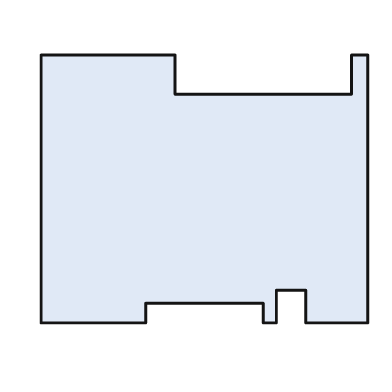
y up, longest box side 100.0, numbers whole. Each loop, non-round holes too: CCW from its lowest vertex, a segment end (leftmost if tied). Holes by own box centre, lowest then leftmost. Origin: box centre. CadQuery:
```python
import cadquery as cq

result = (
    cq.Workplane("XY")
    .moveTo(-50.0, -41.0)
    .lineTo(-18.0, -41.0)
    .lineTo(-18.0, -35.0)
    .lineTo(18.0, -35.0)
    .lineTo(18.0, -41.0)
    .lineTo(22.0, -41.0)
    .lineTo(22.0, -31.0)
    .lineTo(31.0, -31.0)
    .lineTo(31.0, -41.0)
    .lineTo(50.0, -41.0)
    .lineTo(50.0, 41.0)
    .lineTo(45.0, 41.0)
    .lineTo(45.0, 29.0)
    .lineTo(-9.0, 29.0)
    .lineTo(-9.0, 41.0)
    .lineTo(-50.0, 41.0)
    .close()
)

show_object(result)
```